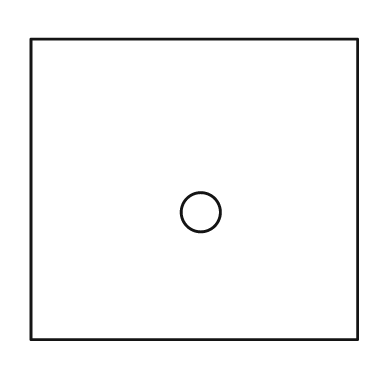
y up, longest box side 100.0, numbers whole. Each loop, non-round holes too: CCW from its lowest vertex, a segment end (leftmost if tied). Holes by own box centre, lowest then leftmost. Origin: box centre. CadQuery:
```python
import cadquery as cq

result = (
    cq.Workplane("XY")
    .moveTo(-50.0, -46.0)
    .lineTo(50.0, -46.0)
    .lineTo(50.0, 46.0)
    .lineTo(-50.0, 46.0)
    .close()
    .moveTo(2.0, -7.0)
    .circle(6.0)
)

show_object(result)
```